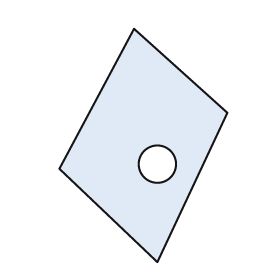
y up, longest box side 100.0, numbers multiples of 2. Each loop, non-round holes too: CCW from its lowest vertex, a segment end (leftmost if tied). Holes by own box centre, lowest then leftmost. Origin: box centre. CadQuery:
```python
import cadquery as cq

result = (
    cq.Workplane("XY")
    .moveTo(6.0, -50.0)
    .lineTo(36.0, 14.0)
    .lineTo(-4.0, 50.0)
    .lineTo(-36.0, -10.0)
    .close()
    .moveTo(6.0, -8.0)
    .circle(8.0)
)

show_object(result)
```